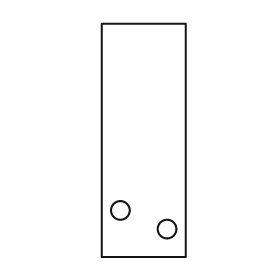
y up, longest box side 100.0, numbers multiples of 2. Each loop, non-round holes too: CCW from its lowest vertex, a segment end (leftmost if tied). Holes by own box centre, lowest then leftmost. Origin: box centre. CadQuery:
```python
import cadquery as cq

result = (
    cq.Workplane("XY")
    .moveTo(-18.0, -50.0)
    .lineTo(18.0, -50.0)
    .lineTo(18.0, 50.0)
    .lineTo(-18.0, 50.0)
    .close()
    .moveTo(10.0, -38.0)
    .circle(4.0)
    .moveTo(-10.0, -30.0)
    .circle(4.0)
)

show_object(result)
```